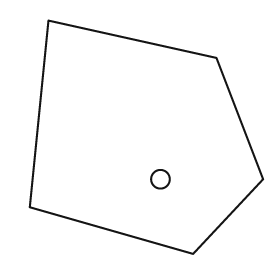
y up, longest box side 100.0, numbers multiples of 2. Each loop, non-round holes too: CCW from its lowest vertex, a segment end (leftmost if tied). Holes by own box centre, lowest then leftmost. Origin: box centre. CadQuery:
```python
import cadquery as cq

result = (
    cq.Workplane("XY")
    .moveTo(20.0, -50.0)
    .lineTo(50.0, -18.0)
    .lineTo(30.0, 34.0)
    .lineTo(-42.0, 50.0)
    .lineTo(-50.0, -30.0)
    .close()
    .moveTo(6.0, -18.0)
    .circle(4.0)
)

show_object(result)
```